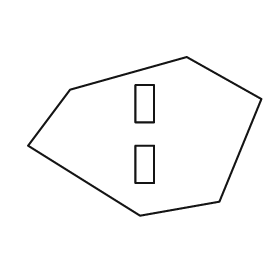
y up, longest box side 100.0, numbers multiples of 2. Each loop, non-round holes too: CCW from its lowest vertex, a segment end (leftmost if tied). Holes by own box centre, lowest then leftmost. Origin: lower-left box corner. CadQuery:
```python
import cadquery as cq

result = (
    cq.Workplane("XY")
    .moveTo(48.0, 0.0)
    .lineTo(82.0, 6.0)
    .lineTo(100.0, 50.0)
    .lineTo(68.0, 68.0)
    .lineTo(18.0, 54.0)
    .lineTo(0.0, 30.0)
    .close()
    .moveTo(46.0, 14.0)
    .lineTo(54.0, 14.0)
    .lineTo(54.0, 30.0)
    .lineTo(46.0, 30.0)
    .close()
    .moveTo(46.0, 40.0)
    .lineTo(54.0, 40.0)
    .lineTo(54.0, 56.0)
    .lineTo(46.0, 56.0)
    .close()
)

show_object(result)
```